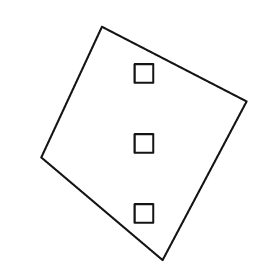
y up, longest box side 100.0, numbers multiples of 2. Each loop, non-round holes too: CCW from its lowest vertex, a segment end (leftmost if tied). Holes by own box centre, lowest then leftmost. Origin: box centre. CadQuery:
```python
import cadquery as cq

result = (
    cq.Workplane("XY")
    .moveTo(8.0, -50.0)
    .lineTo(44.0, 18.0)
    .lineTo(-18.0, 50.0)
    .lineTo(-44.0, -6.0)
    .close()
    .moveTo(-4.0, -34.0)
    .lineTo(4.0, -34.0)
    .lineTo(4.0, -26.0)
    .lineTo(-4.0, -26.0)
    .close()
    .moveTo(-4.0, -4.0)
    .lineTo(4.0, -4.0)
    .lineTo(4.0, 4.0)
    .lineTo(-4.0, 4.0)
    .close()
    .moveTo(-4.0, 26.0)
    .lineTo(4.0, 26.0)
    .lineTo(4.0, 34.0)
    .lineTo(-4.0, 34.0)
    .close()
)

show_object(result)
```